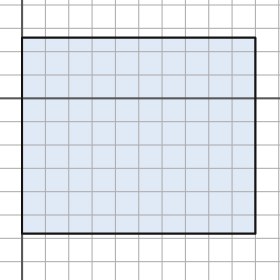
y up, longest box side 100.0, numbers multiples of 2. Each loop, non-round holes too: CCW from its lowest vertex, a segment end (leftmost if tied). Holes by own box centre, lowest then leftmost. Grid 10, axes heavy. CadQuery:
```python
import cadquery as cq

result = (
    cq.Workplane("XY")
    .moveTo(0.0, -58.0)
    .lineTo(100.0, -58.0)
    .lineTo(100.0, 26.0)
    .lineTo(0.0, 26.0)
    .close()
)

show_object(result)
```